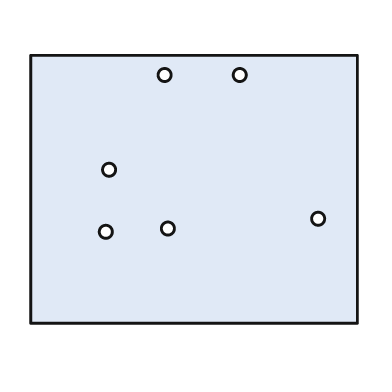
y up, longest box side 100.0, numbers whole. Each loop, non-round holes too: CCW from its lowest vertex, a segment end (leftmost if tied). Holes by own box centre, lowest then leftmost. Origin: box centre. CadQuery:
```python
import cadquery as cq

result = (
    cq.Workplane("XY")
    .moveTo(-50.0, -41.0)
    .lineTo(50.0, -41.0)
    .lineTo(50.0, 41.0)
    .lineTo(-50.0, 41.0)
    .close()
    .moveTo(-27.0, -13.0)
    .circle(2.0)
    .moveTo(-8.0, -12.0)
    .circle(2.0)
    .moveTo(38.0, -9.0)
    .circle(2.0)
    .moveTo(-26.0, 6.0)
    .circle(2.0)
    .moveTo(-9.0, 35.0)
    .circle(2.0)
    .moveTo(14.0, 35.0)
    .circle(2.0)
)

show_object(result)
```